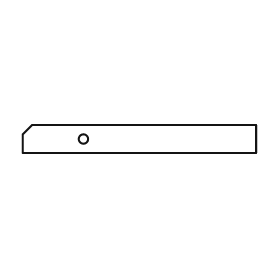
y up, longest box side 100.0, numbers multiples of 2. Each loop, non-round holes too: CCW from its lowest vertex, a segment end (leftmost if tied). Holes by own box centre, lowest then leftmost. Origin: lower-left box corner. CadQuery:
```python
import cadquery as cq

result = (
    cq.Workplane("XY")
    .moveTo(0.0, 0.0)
    .lineTo(100.0, 0.0)
    .lineTo(100.0, 12.0)
    .lineTo(4.0, 12.0)
    .lineTo(0.0, 8.0)
    .close()
    .moveTo(26.0, 6.0)
    .circle(2.0)
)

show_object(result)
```